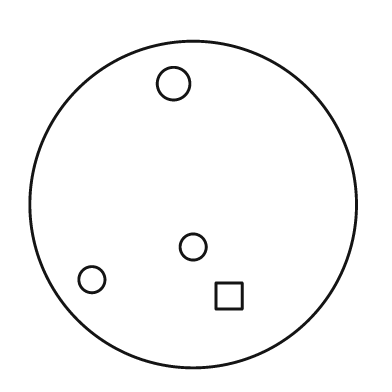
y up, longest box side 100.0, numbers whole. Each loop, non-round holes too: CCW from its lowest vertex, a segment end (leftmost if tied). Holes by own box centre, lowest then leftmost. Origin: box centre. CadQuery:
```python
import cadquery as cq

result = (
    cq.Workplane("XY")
    .moveTo(0.0, 0.0)
    .circle(50.0)
    .moveTo(7.0, -32.0)
    .lineTo(15.0, -32.0)
    .lineTo(15.0, -24.0)
    .lineTo(7.0, -24.0)
    .close()
    .moveTo(-31.0, -23.0)
    .circle(4.0)
    .moveTo(0.0, -13.0)
    .circle(4.0)
    .moveTo(-6.0, 37.0)
    .circle(5.0)
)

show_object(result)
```